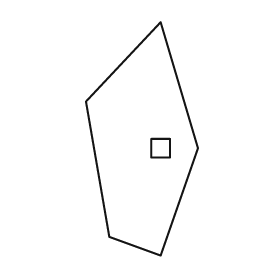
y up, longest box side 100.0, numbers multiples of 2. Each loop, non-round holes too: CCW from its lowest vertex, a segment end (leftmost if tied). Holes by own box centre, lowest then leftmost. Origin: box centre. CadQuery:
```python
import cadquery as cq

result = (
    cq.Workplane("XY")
    .moveTo(8.0, -50.0)
    .lineTo(24.0, -4.0)
    .lineTo(8.0, 50.0)
    .lineTo(-24.0, 16.0)
    .lineTo(-14.0, -42.0)
    .close()
    .moveTo(4.0, -8.0)
    .lineTo(12.0, -8.0)
    .lineTo(12.0, 0.0)
    .lineTo(4.0, 0.0)
    .close()
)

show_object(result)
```